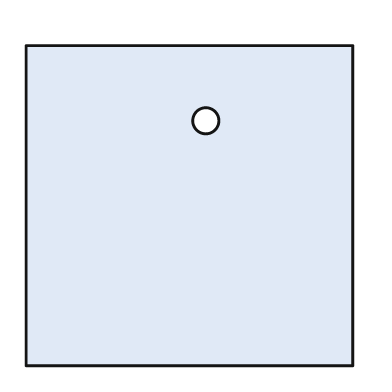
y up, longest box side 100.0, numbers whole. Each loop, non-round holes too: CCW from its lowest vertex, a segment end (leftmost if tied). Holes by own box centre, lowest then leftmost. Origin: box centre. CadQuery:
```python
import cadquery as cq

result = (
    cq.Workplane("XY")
    .moveTo(-50.0, -49.0)
    .lineTo(50.0, -49.0)
    .lineTo(50.0, 49.0)
    .lineTo(-50.0, 49.0)
    .close()
    .moveTo(5.0, 26.0)
    .circle(4.0)
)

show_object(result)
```